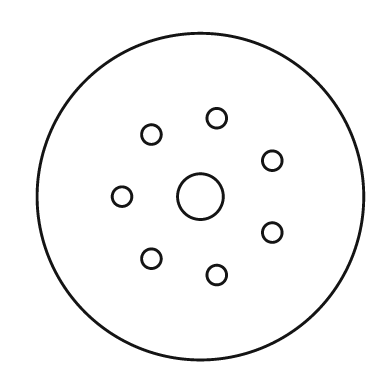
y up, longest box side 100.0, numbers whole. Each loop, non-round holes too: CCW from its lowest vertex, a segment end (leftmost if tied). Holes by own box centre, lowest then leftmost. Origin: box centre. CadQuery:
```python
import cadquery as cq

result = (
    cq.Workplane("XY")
    .moveTo(0.0, 0.0)
    .circle(50.0)
    .moveTo(5.0, -24.0)
    .circle(3.0)
    .moveTo(-15.0, -19.0)
    .circle(3.0)
    .moveTo(22.0, -11.0)
    .circle(3.0)
    .moveTo(-24.0, 0.0)
    .circle(3.0)
    .moveTo(0.0, 0.0)
    .circle(7.0)
    .moveTo(22.0, 11.0)
    .circle(3.0)
    .moveTo(-15.0, 19.0)
    .circle(3.0)
    .moveTo(5.0, 24.0)
    .circle(3.0)
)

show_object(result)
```